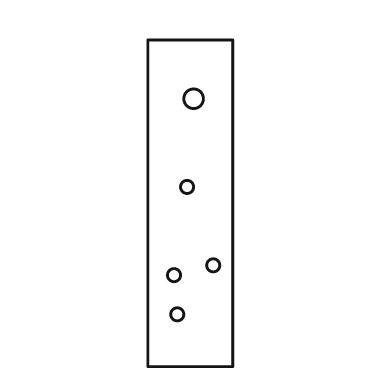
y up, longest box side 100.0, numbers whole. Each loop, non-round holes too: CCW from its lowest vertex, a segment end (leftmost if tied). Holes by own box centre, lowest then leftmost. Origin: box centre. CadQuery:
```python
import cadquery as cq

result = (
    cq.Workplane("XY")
    .moveTo(-13.0, -50.0)
    .lineTo(13.0, -50.0)
    .lineTo(13.0, 50.0)
    .lineTo(-13.0, 50.0)
    .close()
    .moveTo(-4.0, -34.0)
    .circle(2.0)
    .moveTo(-5.0, -22.0)
    .circle(2.0)
    .moveTo(7.0, -19.0)
    .circle(2.0)
    .moveTo(-1.0, 5.0)
    .circle(2.0)
    .moveTo(1.0, 32.0)
    .circle(3.0)
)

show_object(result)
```